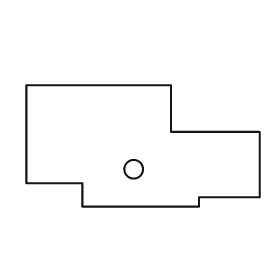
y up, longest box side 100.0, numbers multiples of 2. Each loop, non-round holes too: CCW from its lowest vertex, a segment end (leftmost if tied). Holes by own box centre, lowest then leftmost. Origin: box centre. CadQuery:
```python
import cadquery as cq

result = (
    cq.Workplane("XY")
    .moveTo(-26.0, -26.0)
    .lineTo(24.0, -26.0)
    .lineTo(24.0, -22.0)
    .lineTo(50.0, -22.0)
    .lineTo(50.0, 6.0)
    .lineTo(12.0, 6.0)
    .lineTo(12.0, 26.0)
    .lineTo(-50.0, 26.0)
    .lineTo(-50.0, -16.0)
    .lineTo(-26.0, -16.0)
    .close()
    .moveTo(-4.0, -10.0)
    .circle(4.0)
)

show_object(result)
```